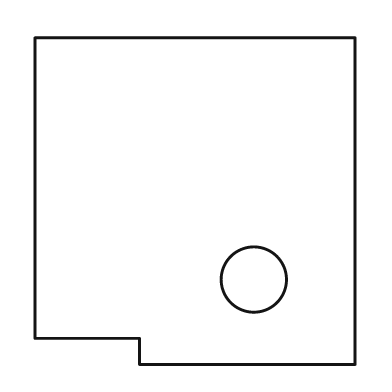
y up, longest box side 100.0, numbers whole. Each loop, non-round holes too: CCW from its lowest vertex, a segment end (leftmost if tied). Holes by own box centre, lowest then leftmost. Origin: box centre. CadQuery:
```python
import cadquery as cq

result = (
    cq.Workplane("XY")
    .moveTo(-17.0, -50.0)
    .lineTo(49.0, -50.0)
    .lineTo(49.0, 50.0)
    .lineTo(-49.0, 50.0)
    .lineTo(-49.0, -42.0)
    .lineTo(-17.0, -42.0)
    .close()
    .moveTo(18.0, -24.0)
    .circle(10.0)
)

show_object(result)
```